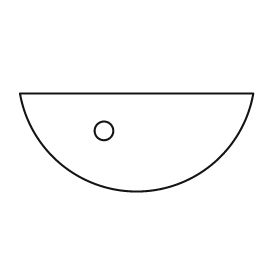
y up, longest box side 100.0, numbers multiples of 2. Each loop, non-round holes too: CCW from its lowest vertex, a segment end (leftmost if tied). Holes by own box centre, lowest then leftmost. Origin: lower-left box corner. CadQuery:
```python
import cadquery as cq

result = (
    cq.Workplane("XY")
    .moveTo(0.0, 42.0)
    .threePointArc((50.0, 0.0), (100.0, 42.0))
    .close()
    .moveTo(36.0, 26.0)
    .circle(4.0)
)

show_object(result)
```